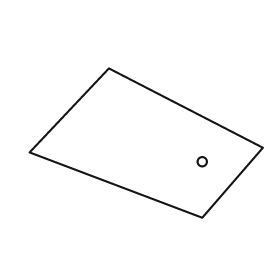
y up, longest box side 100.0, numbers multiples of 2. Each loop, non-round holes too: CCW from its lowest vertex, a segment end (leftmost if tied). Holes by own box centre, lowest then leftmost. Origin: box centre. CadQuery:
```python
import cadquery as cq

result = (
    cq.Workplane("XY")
    .moveTo(24.0, -32.0)
    .lineTo(50.0, -2.0)
    .lineTo(-16.0, 32.0)
    .lineTo(-50.0, -4.0)
    .close()
    .moveTo(24.0, -8.0)
    .circle(2.0)
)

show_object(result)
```